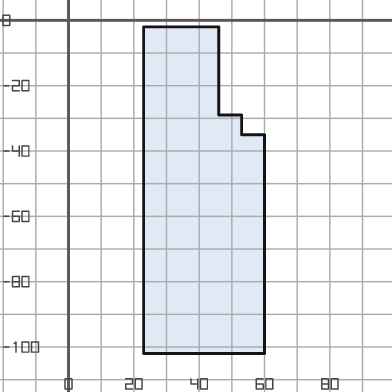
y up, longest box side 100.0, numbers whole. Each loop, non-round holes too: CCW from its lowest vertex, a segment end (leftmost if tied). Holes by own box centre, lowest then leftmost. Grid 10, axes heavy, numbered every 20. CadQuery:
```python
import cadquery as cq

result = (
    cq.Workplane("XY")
    .moveTo(23.0, -102.0)
    .lineTo(60.0, -102.0)
    .lineTo(60.0, -35.0)
    .lineTo(53.0, -35.0)
    .lineTo(53.0, -29.0)
    .lineTo(46.0, -29.0)
    .lineTo(46.0, -2.0)
    .lineTo(23.0, -2.0)
    .close()
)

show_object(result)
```